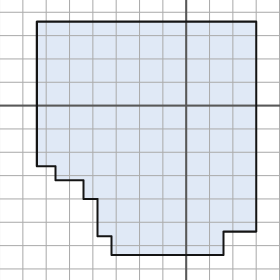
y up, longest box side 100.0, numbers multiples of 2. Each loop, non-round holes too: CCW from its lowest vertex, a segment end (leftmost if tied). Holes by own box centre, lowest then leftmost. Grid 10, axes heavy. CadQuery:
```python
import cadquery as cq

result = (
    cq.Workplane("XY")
    .moveTo(-32.0, -64.0)
    .lineTo(16.0, -64.0)
    .lineTo(16.0, -54.0)
    .lineTo(30.0, -54.0)
    .lineTo(30.0, 36.0)
    .lineTo(-64.0, 36.0)
    .lineTo(-64.0, -26.0)
    .lineTo(-56.0, -26.0)
    .lineTo(-56.0, -32.0)
    .lineTo(-44.0, -32.0)
    .lineTo(-44.0, -40.0)
    .lineTo(-38.0, -40.0)
    .lineTo(-38.0, -56.0)
    .lineTo(-32.0, -56.0)
    .close()
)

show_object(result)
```